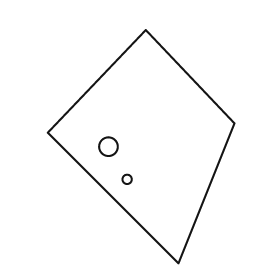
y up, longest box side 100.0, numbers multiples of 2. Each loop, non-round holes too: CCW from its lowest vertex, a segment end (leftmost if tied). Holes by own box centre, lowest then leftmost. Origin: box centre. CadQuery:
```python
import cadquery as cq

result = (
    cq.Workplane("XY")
    .moveTo(16.0, -50.0)
    .lineTo(40.0, 10.0)
    .lineTo(2.0, 50.0)
    .lineTo(-40.0, 6.0)
    .close()
    .moveTo(-6.0, -14.0)
    .circle(2.0)
    .moveTo(-14.0, 0.0)
    .circle(4.0)
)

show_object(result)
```